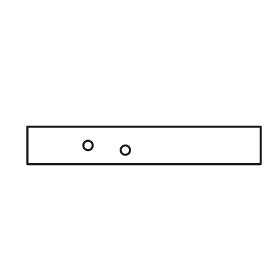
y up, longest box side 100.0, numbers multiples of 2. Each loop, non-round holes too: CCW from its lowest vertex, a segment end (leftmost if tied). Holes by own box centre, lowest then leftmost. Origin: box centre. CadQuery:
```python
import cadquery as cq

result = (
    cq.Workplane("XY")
    .moveTo(-50.0, -8.0)
    .lineTo(50.0, -8.0)
    .lineTo(50.0, 8.0)
    .lineTo(-50.0, 8.0)
    .close()
    .moveTo(-8.0, -2.0)
    .circle(2.0)
    .moveTo(-24.0, 0.0)
    .circle(2.0)
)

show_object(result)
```